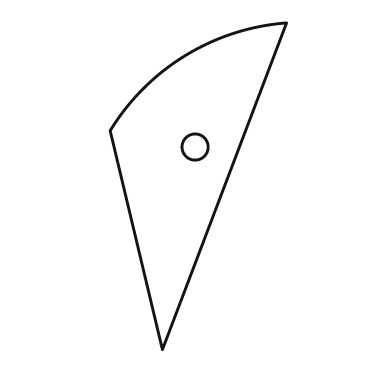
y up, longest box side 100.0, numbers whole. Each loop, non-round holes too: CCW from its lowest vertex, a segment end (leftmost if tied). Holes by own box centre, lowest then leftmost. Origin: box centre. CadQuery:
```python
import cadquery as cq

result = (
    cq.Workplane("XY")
    .moveTo(-11.0, -50.0)
    .lineTo(27.0, 50.0)
    .threePointArc((-4.0, 40.0), (-27.0, 17.0))
    .close()
    .moveTo(-1.0, 12.0)
    .circle(4.0)
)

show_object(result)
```